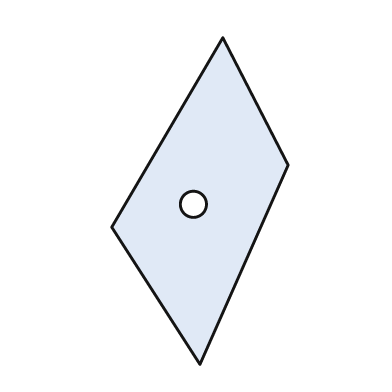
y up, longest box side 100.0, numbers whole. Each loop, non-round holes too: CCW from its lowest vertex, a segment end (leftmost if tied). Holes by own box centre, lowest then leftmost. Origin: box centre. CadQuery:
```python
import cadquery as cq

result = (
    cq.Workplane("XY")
    .moveTo(0.0, -50.0)
    .lineTo(27.0, 11.0)
    .lineTo(7.0, 50.0)
    .lineTo(-27.0, -8.0)
    .close()
    .moveTo(-2.0, -1.0)
    .circle(4.0)
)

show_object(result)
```